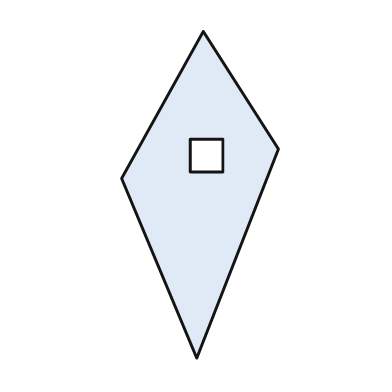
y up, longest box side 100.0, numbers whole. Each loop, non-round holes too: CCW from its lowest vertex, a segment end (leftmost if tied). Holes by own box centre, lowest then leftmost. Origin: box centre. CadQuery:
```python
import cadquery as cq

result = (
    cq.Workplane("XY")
    .moveTo(-1.0, -50.0)
    .lineTo(24.0, 14.0)
    .lineTo(1.0, 50.0)
    .lineTo(-24.0, 5.0)
    .close()
    .moveTo(-3.0, 7.0)
    .lineTo(7.0, 7.0)
    .lineTo(7.0, 17.0)
    .lineTo(-3.0, 17.0)
    .close()
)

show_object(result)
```